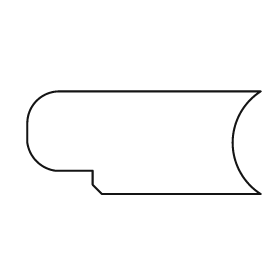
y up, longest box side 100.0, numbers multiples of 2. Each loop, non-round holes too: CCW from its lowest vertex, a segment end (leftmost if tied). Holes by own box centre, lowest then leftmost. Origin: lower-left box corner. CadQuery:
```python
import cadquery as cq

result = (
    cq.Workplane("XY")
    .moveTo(32.0, 0.0)
    .lineTo(100.0, 0.0)
    .threePointArc((88.0, 22.0), (100.0, 44.0))
    .lineTo(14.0, 44.0)
    .threePointArc((4.0, 40.0), (0.0, 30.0))
    .lineTo(0.0, 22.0)
    .threePointArc((4.0, 14.0), (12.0, 10.0))
    .lineTo(28.0, 10.0)
    .lineTo(28.0, 4.0)
    .close()
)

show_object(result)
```